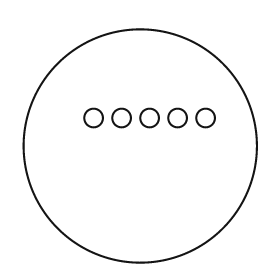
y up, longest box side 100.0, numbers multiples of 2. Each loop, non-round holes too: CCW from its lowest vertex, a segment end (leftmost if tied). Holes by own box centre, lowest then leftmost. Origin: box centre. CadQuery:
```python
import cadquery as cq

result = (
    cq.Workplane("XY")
    .moveTo(0.0, 0.0)
    .circle(50.0)
    .moveTo(-20.0, 12.0)
    .circle(4.0)
    .moveTo(-8.0, 12.0)
    .circle(4.0)
    .moveTo(4.0, 12.0)
    .circle(4.0)
    .moveTo(16.0, 12.0)
    .circle(4.0)
    .moveTo(28.0, 12.0)
    .circle(4.0)
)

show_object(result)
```